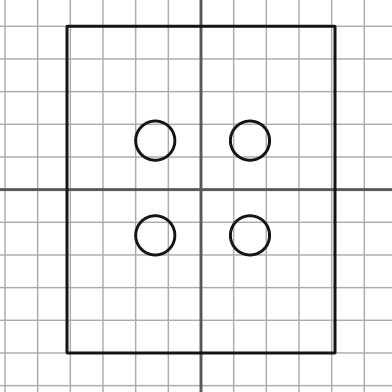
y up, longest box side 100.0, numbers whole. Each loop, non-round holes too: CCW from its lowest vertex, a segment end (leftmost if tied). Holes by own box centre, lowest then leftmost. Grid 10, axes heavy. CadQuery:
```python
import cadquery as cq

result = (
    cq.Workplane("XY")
    .moveTo(-41.0, -50.0)
    .lineTo(41.0, -50.0)
    .lineTo(41.0, 50.0)
    .lineTo(-41.0, 50.0)
    .close()
    .moveTo(-14.0, -14.0)
    .circle(6.0)
    .moveTo(15.0, -14.0)
    .circle(6.0)
    .moveTo(-14.0, 15.0)
    .circle(6.0)
    .moveTo(15.0, 15.0)
    .circle(6.0)
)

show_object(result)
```